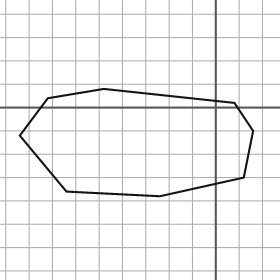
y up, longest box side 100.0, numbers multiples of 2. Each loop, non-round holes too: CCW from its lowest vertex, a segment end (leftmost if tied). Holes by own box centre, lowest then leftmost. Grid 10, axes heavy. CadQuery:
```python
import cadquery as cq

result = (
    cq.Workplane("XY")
    .moveTo(-24.0, -38.0)
    .lineTo(12.0, -30.0)
    .lineTo(16.0, -10.0)
    .lineTo(8.0, 2.0)
    .lineTo(-48.0, 8.0)
    .lineTo(-72.0, 4.0)
    .lineTo(-84.0, -12.0)
    .lineTo(-64.0, -36.0)
    .close()
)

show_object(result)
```